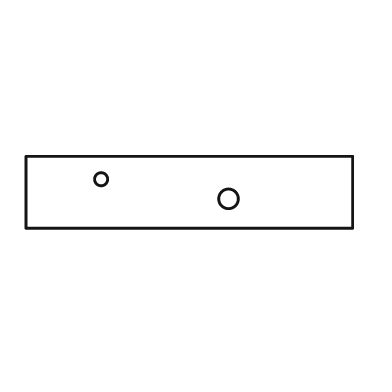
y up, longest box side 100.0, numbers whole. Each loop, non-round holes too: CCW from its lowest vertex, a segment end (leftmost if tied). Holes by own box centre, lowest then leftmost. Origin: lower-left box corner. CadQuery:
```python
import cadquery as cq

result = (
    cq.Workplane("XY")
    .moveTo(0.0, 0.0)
    .lineTo(100.0, 0.0)
    .lineTo(100.0, 22.0)
    .lineTo(0.0, 22.0)
    .close()
    .moveTo(62.0, 9.0)
    .circle(3.0)
    .moveTo(23.0, 15.0)
    .circle(2.0)
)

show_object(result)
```